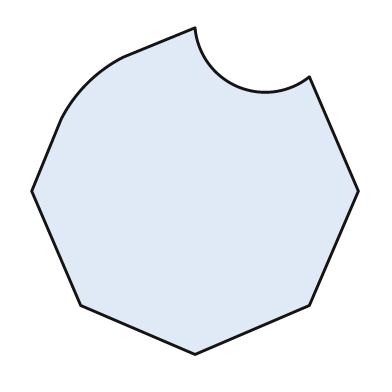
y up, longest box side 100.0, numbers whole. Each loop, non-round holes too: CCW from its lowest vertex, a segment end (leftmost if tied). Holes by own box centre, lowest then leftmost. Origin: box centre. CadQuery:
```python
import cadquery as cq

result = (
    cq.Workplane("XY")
    .moveTo(0.0, -50.0)
    .lineTo(35.0, -35.0)
    .lineTo(50.0, 0.0)
    .lineTo(35.0, 35.0)
    .threePointArc((13.0, 32.0), (0.0, 50.0))
    .lineTo(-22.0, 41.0)
    .threePointArc((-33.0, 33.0), (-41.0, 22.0))
    .lineTo(-50.0, 0.0)
    .lineTo(-35.0, -35.0)
    .close()
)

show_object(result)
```